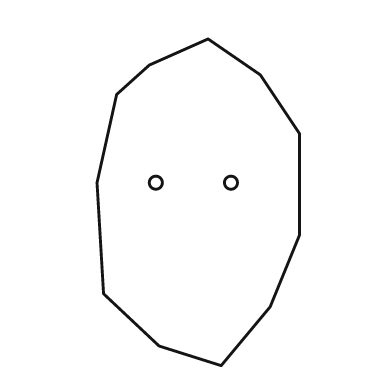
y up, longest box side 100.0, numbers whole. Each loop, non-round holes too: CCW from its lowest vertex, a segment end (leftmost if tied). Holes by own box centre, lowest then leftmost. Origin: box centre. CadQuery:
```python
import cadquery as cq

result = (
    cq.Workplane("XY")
    .moveTo(7.0, -50.0)
    .lineTo(22.0, -32.0)
    .lineTo(31.0, -10.0)
    .lineTo(31.0, 21.0)
    .lineTo(19.0, 39.0)
    .lineTo(3.0, 50.0)
    .lineTo(-15.0, 42.0)
    .lineTo(-25.0, 33.0)
    .lineTo(-31.0, 6.0)
    .lineTo(-29.0, -28.0)
    .lineTo(-12.0, -44.0)
    .close()
    .moveTo(-13.0, 6.0)
    .circle(2.0)
    .moveTo(10.0, 6.0)
    .circle(2.0)
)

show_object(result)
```